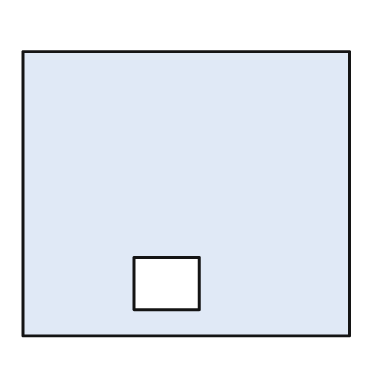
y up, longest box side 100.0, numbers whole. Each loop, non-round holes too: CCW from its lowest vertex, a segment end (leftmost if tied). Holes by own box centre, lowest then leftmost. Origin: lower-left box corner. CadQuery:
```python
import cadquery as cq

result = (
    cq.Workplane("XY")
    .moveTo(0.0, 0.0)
    .lineTo(100.0, 0.0)
    .lineTo(100.0, 87.0)
    .lineTo(0.0, 87.0)
    .close()
    .moveTo(34.0, 8.0)
    .lineTo(54.0, 8.0)
    .lineTo(54.0, 24.0)
    .lineTo(34.0, 24.0)
    .close()
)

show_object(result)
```